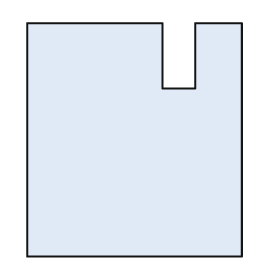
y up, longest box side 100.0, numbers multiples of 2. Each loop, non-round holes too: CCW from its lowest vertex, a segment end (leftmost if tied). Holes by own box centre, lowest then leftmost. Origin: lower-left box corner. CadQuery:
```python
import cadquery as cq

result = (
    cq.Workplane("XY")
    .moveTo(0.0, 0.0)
    .lineTo(92.0, 0.0)
    .lineTo(92.0, 100.0)
    .lineTo(72.0, 100.0)
    .lineTo(72.0, 72.0)
    .lineTo(58.0, 72.0)
    .lineTo(58.0, 100.0)
    .lineTo(0.0, 100.0)
    .close()
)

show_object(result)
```